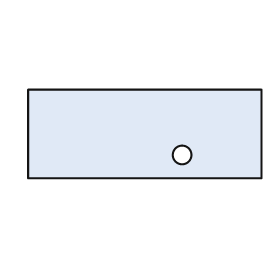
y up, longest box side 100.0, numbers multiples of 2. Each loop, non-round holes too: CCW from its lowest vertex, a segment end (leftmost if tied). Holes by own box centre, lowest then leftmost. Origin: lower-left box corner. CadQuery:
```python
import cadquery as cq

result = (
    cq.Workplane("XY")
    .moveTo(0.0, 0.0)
    .lineTo(100.0, 0.0)
    .lineTo(100.0, 38.0)
    .lineTo(0.0, 38.0)
    .close()
    .moveTo(66.0, 10.0)
    .circle(4.0)
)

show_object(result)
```